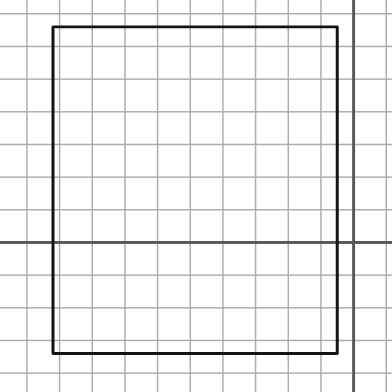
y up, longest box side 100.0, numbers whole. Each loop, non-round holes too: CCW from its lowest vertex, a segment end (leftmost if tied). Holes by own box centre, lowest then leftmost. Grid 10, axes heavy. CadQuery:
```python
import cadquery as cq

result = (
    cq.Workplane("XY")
    .moveTo(-92.0, -34.0)
    .lineTo(-5.0, -34.0)
    .lineTo(-5.0, 66.0)
    .lineTo(-92.0, 66.0)
    .close()
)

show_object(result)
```